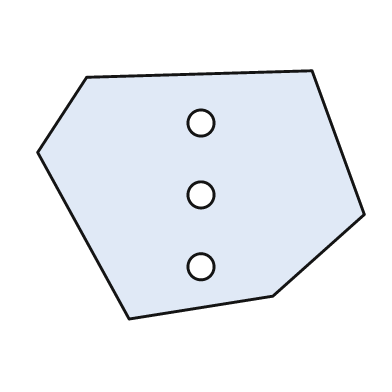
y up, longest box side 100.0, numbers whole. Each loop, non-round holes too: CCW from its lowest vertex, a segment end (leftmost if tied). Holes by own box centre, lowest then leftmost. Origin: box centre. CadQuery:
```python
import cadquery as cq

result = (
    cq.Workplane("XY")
    .moveTo(-22.0, -38.0)
    .lineTo(22.0, -31.0)
    .lineTo(50.0, -6.0)
    .lineTo(34.0, 38.0)
    .lineTo(-35.0, 36.0)
    .lineTo(-50.0, 13.0)
    .close()
    .moveTo(0.0, -22.0)
    .circle(4.0)
    .moveTo(0.0, 0.0)
    .circle(4.0)
    .moveTo(0.0, 22.0)
    .circle(4.0)
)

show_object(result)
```